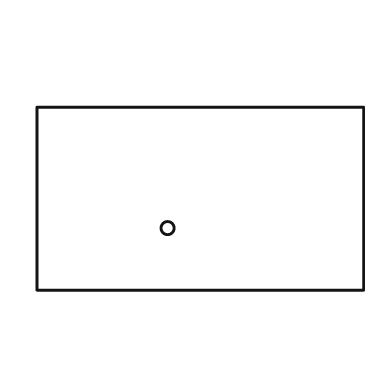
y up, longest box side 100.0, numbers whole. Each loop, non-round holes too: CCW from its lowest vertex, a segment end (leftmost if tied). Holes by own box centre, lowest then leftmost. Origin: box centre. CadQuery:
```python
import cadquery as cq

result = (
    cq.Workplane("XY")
    .moveTo(-50.0, -28.0)
    .lineTo(50.0, -28.0)
    .lineTo(50.0, 28.0)
    .lineTo(-50.0, 28.0)
    .close()
    .moveTo(-10.0, -9.0)
    .circle(2.0)
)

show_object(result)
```